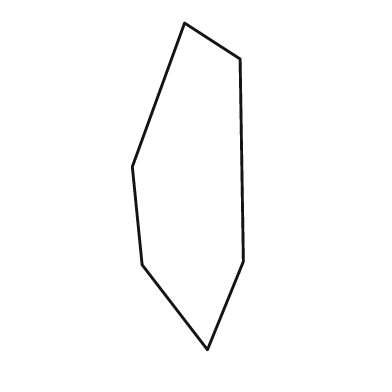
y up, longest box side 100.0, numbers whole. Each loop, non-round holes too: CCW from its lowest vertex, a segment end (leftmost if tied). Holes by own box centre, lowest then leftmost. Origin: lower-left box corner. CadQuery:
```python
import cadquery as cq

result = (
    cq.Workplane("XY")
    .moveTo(23.0, 0.0)
    .lineTo(34.0, 27.0)
    .lineTo(33.0, 89.0)
    .lineTo(16.0, 100.0)
    .lineTo(0.0, 56.0)
    .lineTo(3.0, 26.0)
    .close()
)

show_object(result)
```